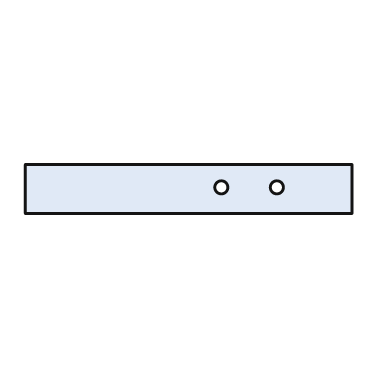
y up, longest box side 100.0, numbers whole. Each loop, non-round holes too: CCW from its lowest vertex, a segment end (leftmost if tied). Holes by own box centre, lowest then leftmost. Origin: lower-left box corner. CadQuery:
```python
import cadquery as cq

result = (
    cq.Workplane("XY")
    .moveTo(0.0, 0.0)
    .lineTo(100.0, 0.0)
    .lineTo(100.0, 15.0)
    .lineTo(0.0, 15.0)
    .close()
    .moveTo(60.0, 8.0)
    .circle(2.0)
    .moveTo(77.0, 8.0)
    .circle(2.0)
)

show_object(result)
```